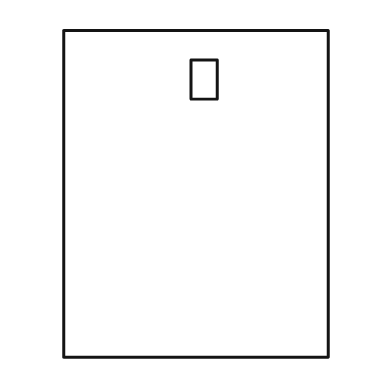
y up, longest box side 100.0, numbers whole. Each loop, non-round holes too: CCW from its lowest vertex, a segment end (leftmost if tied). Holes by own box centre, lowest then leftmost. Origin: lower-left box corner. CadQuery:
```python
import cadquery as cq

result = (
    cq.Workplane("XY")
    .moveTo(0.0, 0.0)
    .lineTo(81.0, 0.0)
    .lineTo(81.0, 100.0)
    .lineTo(0.0, 100.0)
    .close()
    .moveTo(39.0, 79.0)
    .lineTo(47.0, 79.0)
    .lineTo(47.0, 91.0)
    .lineTo(39.0, 91.0)
    .close()
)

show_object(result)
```